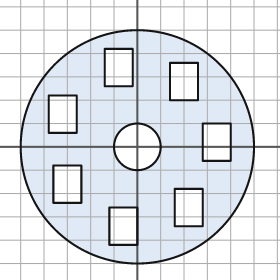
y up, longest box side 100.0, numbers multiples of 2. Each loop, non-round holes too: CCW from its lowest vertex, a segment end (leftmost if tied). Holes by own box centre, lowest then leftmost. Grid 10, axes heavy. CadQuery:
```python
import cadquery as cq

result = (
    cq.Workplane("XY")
    .moveTo(0.0, 0.0)
    .circle(50.0)
    .moveTo(-12.0, -42.0)
    .lineTo(0.0, -42.0)
    .lineTo(0.0, -26.0)
    .lineTo(-12.0, -26.0)
    .close()
    .moveTo(16.0, -34.0)
    .lineTo(28.0, -34.0)
    .lineTo(28.0, -18.0)
    .lineTo(16.0, -18.0)
    .close()
    .moveTo(-36.0, -24.0)
    .lineTo(-24.0, -24.0)
    .lineTo(-24.0, -8.0)
    .lineTo(-36.0, -8.0)
    .close()
    .moveTo(0.0, 0.0)
    .circle(10.0)
    .moveTo(28.0, -6.0)
    .lineTo(40.0, -6.0)
    .lineTo(40.0, 10.0)
    .lineTo(28.0, 10.0)
    .close()
    .moveTo(-38.0, 6.0)
    .lineTo(-26.0, 6.0)
    .lineTo(-26.0, 22.0)
    .lineTo(-38.0, 22.0)
    .close()
    .moveTo(14.0, 20.0)
    .lineTo(26.0, 20.0)
    .lineTo(26.0, 36.0)
    .lineTo(14.0, 36.0)
    .close()
    .moveTo(-14.0, 26.0)
    .lineTo(-2.0, 26.0)
    .lineTo(-2.0, 42.0)
    .lineTo(-14.0, 42.0)
    .close()
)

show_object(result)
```